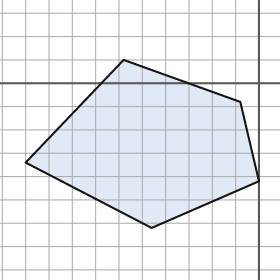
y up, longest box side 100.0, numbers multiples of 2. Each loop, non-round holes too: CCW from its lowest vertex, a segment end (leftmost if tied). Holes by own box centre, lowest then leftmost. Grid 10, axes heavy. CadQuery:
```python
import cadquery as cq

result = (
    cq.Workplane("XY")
    .moveTo(-46.0, -62.0)
    .lineTo(0.0, -42.0)
    .lineTo(-8.0, -8.0)
    .lineTo(-58.0, 10.0)
    .lineTo(-100.0, -34.0)
    .close()
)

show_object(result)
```